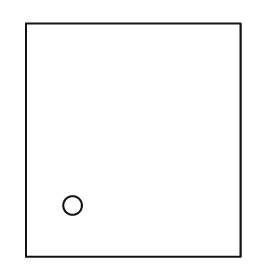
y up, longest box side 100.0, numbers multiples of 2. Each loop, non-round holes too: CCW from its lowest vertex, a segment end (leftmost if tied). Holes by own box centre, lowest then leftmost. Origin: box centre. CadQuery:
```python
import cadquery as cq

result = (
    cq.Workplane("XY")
    .moveTo(-46.0, -50.0)
    .lineTo(46.0, -50.0)
    .lineTo(46.0, 50.0)
    .lineTo(-46.0, 50.0)
    .close()
    .moveTo(-26.0, -28.0)
    .circle(4.0)
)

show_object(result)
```